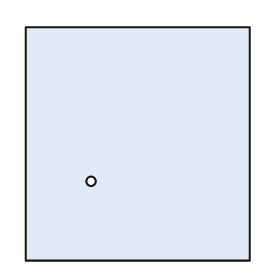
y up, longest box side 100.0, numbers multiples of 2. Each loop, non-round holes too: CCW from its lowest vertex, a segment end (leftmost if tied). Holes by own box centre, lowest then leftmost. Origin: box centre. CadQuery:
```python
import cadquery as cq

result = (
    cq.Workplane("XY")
    .moveTo(-48.0, -50.0)
    .lineTo(48.0, -50.0)
    .lineTo(48.0, 50.0)
    .lineTo(-48.0, 50.0)
    .close()
    .moveTo(-20.0, -16.0)
    .circle(2.0)
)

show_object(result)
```